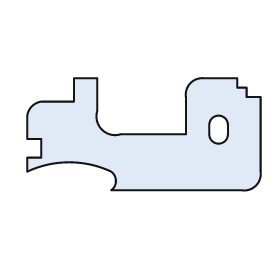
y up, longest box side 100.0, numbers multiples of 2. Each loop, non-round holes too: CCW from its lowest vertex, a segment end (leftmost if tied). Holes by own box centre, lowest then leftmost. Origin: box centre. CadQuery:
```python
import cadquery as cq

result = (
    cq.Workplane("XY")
    .moveTo(-14.0, -24.0)
    .lineTo(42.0, -24.0)
    .threePointArc((48.0, -22.0), (50.0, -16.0))
    .lineTo(50.0, 16.0)
    .lineTo(44.0, 16.0)
    .lineTo(44.0, 20.0)
    .lineTo(40.0, 20.0)
    .lineTo(40.0, 24.0)
    .lineTo(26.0, 24.0)
    .threePointArc((20.0, 22.0), (18.0, 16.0))
    .lineTo(18.0, 0.0)
    .lineTo(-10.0, 0.0)
    .threePointArc((-18.0, 2.0), (-20.0, 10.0))
    .lineTo(-20.0, 24.0)
    .lineTo(-30.0, 24.0)
    .lineTo(-30.0, 14.0)
    .lineTo(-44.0, 14.0)
    .threePointArc((-48.0, 12.0), (-50.0, 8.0))
    .lineTo(-50.0, -2.0)
    .lineTo(-44.0, -2.0)
    .lineTo(-44.0, -10.0)
    .lineTo(-50.0, -10.0)
    .lineTo(-50.0, -16.0)
    .threePointArc((-32.0, -12.0), (-14.0, -16.0))
    .threePointArc((-12.0, -20.0), (-14.0, -24.0))
    .close()
    .moveTo(28.0, 0.0)
    .threePointArc((32.0, -4.0), (36.0, 0.0))
    .lineTo(36.0, 4.0)
    .threePointArc((32.0, 8.0), (28.0, 4.0))
    .close()
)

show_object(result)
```